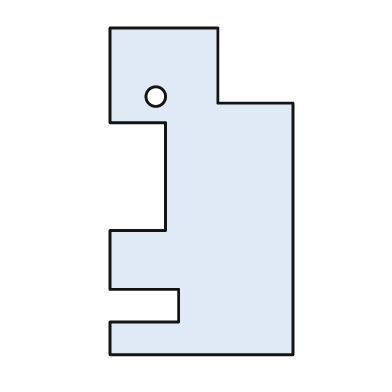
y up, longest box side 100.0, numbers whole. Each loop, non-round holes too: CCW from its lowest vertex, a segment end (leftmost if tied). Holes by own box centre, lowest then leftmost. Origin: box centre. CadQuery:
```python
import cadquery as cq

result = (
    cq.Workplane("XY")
    .moveTo(-28.0, -50.0)
    .lineTo(28.0, -50.0)
    .lineTo(28.0, 27.0)
    .lineTo(5.0, 27.0)
    .lineTo(5.0, 50.0)
    .lineTo(-28.0, 50.0)
    .lineTo(-28.0, 21.0)
    .lineTo(-11.0, 21.0)
    .lineTo(-11.0, -12.0)
    .lineTo(-28.0, -12.0)
    .lineTo(-28.0, -30.0)
    .lineTo(-7.0, -30.0)
    .lineTo(-7.0, -40.0)
    .lineTo(-28.0, -40.0)
    .close()
    .moveTo(-14.0, 29.0)
    .circle(3.0)
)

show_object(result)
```